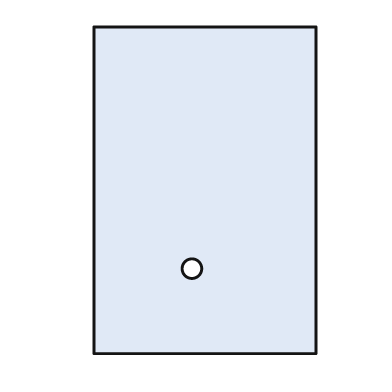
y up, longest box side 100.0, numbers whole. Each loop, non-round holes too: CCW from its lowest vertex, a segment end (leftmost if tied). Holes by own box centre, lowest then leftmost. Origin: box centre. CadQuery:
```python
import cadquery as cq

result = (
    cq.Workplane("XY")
    .moveTo(-34.0, -50.0)
    .lineTo(34.0, -50.0)
    .lineTo(34.0, 50.0)
    .lineTo(-34.0, 50.0)
    .close()
    .moveTo(-4.0, -24.0)
    .circle(3.0)
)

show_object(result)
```